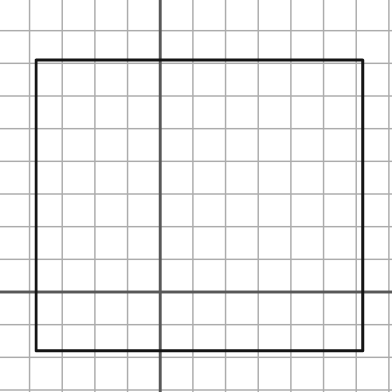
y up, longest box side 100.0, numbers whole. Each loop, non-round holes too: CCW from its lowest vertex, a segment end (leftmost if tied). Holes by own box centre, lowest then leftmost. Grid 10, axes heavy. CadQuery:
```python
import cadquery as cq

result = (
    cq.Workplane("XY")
    .moveTo(-38.0, -18.0)
    .lineTo(62.0, -18.0)
    .lineTo(62.0, 71.0)
    .lineTo(-38.0, 71.0)
    .close()
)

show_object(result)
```